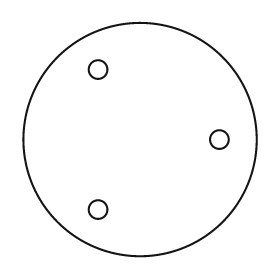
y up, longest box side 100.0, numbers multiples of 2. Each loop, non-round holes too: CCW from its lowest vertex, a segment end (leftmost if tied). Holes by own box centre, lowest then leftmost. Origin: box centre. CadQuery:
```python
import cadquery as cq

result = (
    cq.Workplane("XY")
    .moveTo(0.0, 0.0)
    .circle(50.0)
    .moveTo(-18.0, -30.0)
    .circle(4.0)
    .moveTo(34.0, 0.0)
    .circle(4.0)
    .moveTo(-18.0, 30.0)
    .circle(4.0)
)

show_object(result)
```